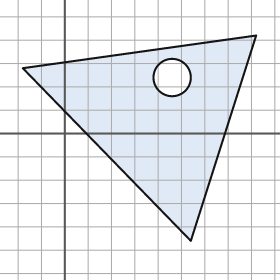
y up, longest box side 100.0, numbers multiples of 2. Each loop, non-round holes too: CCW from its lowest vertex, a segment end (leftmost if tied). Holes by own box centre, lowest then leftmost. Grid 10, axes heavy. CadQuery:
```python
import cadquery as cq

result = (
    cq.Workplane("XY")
    .moveTo(54.0, -46.0)
    .lineTo(82.0, 42.0)
    .lineTo(-18.0, 28.0)
    .close()
    .moveTo(46.0, 24.0)
    .circle(8.0)
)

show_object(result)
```